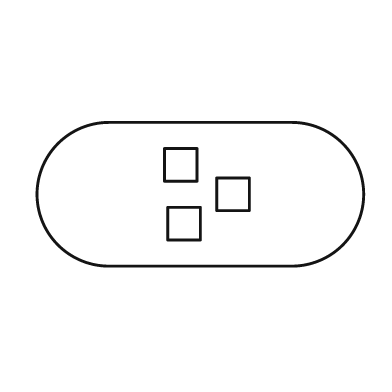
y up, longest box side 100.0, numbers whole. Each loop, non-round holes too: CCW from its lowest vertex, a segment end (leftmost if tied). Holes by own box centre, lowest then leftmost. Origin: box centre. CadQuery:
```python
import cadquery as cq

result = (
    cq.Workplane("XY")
    .moveTo(-28.0, -22.0)
    .lineTo(28.0, -22.0)
    .threePointArc((50.0, 0.0), (28.0, 22.0))
    .lineTo(-28.0, 22.0)
    .threePointArc((-50.0, 0.0), (-28.0, -22.0))
    .close()
    .moveTo(-10.0, -14.0)
    .lineTo(0.0, -14.0)
    .lineTo(0.0, -4.0)
    .lineTo(-10.0, -4.0)
    .close()
    .moveTo(5.0, -5.0)
    .lineTo(15.0, -5.0)
    .lineTo(15.0, 5.0)
    .lineTo(5.0, 5.0)
    .close()
    .moveTo(-11.0, 4.0)
    .lineTo(-1.0, 4.0)
    .lineTo(-1.0, 14.0)
    .lineTo(-11.0, 14.0)
    .close()
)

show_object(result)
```